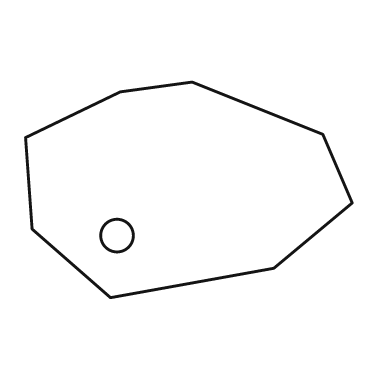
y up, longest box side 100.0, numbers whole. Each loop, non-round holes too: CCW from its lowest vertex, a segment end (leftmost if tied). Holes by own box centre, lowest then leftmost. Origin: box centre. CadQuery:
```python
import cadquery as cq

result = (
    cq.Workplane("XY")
    .moveTo(-24.0, -33.0)
    .lineTo(26.0, -24.0)
    .lineTo(50.0, -4.0)
    .lineTo(41.0, 17.0)
    .lineTo(1.0, 33.0)
    .lineTo(-21.0, 30.0)
    .lineTo(-50.0, 16.0)
    .lineTo(-48.0, -12.0)
    .close()
    .moveTo(-22.0, -14.0)
    .circle(5.0)
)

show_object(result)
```